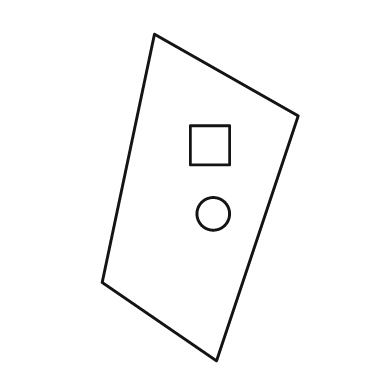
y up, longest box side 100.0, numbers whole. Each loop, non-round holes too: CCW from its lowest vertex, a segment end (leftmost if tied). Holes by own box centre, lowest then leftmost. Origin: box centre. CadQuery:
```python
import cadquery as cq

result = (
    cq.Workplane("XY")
    .moveTo(5.0, -50.0)
    .lineTo(30.0, 25.0)
    .lineTo(-14.0, 50.0)
    .lineTo(-30.0, -26.0)
    .close()
    .moveTo(4.0, -5.0)
    .circle(5.0)
    .moveTo(-3.0, 10.0)
    .lineTo(9.0, 10.0)
    .lineTo(9.0, 22.0)
    .lineTo(-3.0, 22.0)
    .close()
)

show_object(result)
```